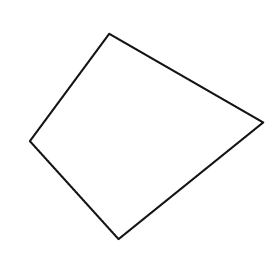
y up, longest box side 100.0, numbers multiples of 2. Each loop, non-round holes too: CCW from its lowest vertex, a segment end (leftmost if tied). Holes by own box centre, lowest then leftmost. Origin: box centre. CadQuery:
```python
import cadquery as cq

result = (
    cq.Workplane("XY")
    .moveTo(-12.0, -44.0)
    .lineTo(50.0, 6.0)
    .lineTo(-16.0, 44.0)
    .lineTo(-50.0, -2.0)
    .close()
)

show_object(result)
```